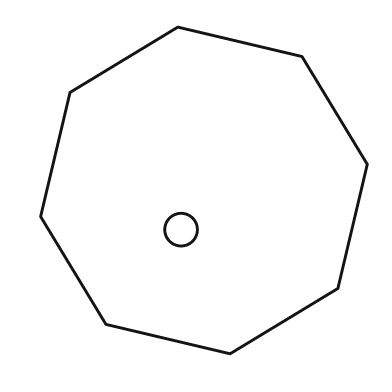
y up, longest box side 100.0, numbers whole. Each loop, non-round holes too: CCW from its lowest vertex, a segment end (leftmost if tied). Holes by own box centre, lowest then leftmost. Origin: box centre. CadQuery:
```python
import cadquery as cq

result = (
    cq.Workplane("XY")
    .moveTo(8.0, -50.0)
    .lineTo(41.0, -30.0)
    .lineTo(50.0, 8.0)
    .lineTo(30.0, 41.0)
    .lineTo(-8.0, 50.0)
    .lineTo(-41.0, 30.0)
    .lineTo(-50.0, -8.0)
    .lineTo(-30.0, -41.0)
    .close()
    .moveTo(-7.0, -12.0)
    .circle(5.0)
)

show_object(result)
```